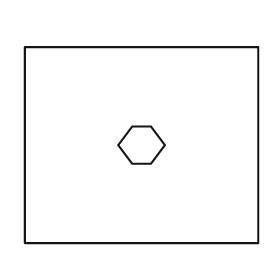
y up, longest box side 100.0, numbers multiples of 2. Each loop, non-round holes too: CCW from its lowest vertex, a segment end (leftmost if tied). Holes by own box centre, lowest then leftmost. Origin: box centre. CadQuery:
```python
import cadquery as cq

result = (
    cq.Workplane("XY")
    .moveTo(-50.0, -42.0)
    .lineTo(50.0, -42.0)
    .lineTo(50.0, 42.0)
    .lineTo(-50.0, 42.0)
    .close()
    .moveTo(-4.0, -8.0)
    .lineTo(4.0, -8.0)
    .lineTo(10.0, 0.0)
    .lineTo(4.0, 8.0)
    .lineTo(-4.0, 8.0)
    .lineTo(-10.0, 0.0)
    .close()
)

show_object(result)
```